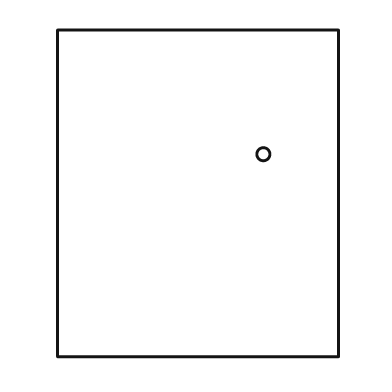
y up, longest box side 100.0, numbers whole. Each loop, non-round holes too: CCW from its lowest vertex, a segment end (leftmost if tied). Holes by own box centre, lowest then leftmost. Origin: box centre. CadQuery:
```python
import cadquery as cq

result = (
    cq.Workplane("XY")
    .moveTo(-43.0, -50.0)
    .lineTo(43.0, -50.0)
    .lineTo(43.0, 50.0)
    .lineTo(-43.0, 50.0)
    .close()
    .moveTo(20.0, 12.0)
    .circle(2.0)
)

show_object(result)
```